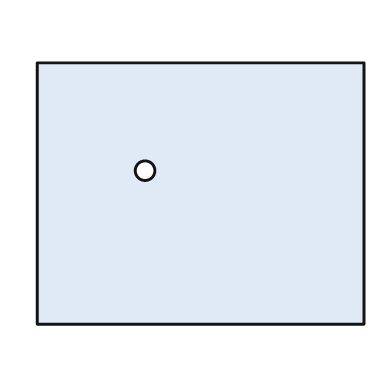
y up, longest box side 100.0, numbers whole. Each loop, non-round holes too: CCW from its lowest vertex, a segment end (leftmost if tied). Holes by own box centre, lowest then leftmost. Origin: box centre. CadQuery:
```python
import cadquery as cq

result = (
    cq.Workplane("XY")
    .moveTo(-50.0, -40.0)
    .lineTo(50.0, -40.0)
    .lineTo(50.0, 40.0)
    .lineTo(-50.0, 40.0)
    .close()
    .moveTo(-17.0, 7.0)
    .circle(3.0)
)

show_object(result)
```